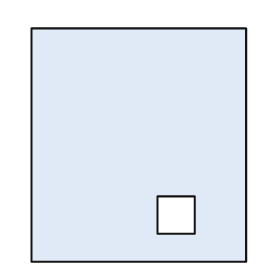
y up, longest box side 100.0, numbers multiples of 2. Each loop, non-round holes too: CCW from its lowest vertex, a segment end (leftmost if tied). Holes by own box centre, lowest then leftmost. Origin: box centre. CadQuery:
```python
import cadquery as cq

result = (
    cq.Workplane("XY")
    .moveTo(-46.0, -50.0)
    .lineTo(46.0, -50.0)
    .lineTo(46.0, 50.0)
    .lineTo(-46.0, 50.0)
    .close()
    .moveTo(8.0, -38.0)
    .lineTo(24.0, -38.0)
    .lineTo(24.0, -22.0)
    .lineTo(8.0, -22.0)
    .close()
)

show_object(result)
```